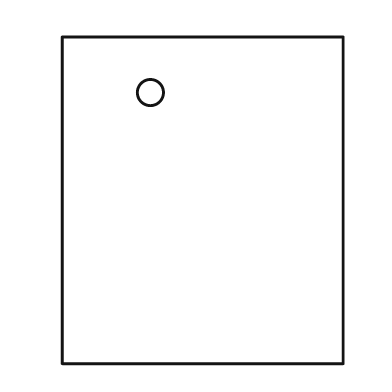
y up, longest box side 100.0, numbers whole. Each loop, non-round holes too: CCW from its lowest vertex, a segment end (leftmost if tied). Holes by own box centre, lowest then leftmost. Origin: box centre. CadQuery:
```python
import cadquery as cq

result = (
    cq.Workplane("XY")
    .moveTo(-43.0, -50.0)
    .lineTo(43.0, -50.0)
    .lineTo(43.0, 50.0)
    .lineTo(-43.0, 50.0)
    .close()
    .moveTo(-16.0, 33.0)
    .circle(4.0)
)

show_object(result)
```